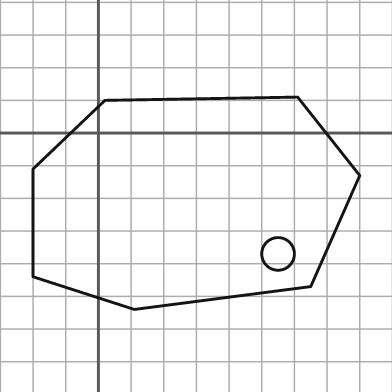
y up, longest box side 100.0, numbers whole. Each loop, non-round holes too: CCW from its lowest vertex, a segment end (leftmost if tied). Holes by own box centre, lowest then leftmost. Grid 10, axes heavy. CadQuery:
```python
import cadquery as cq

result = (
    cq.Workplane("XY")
    .moveTo(11.0, -54.0)
    .lineTo(65.0, -47.0)
    .lineTo(80.0, -13.0)
    .lineTo(61.0, 11.0)
    .lineTo(2.0, 10.0)
    .lineTo(-20.0, -11.0)
    .lineTo(-20.0, -44.0)
    .close()
    .moveTo(55.0, -37.0)
    .circle(5.0)
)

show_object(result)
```